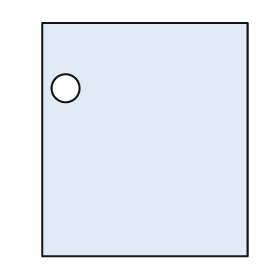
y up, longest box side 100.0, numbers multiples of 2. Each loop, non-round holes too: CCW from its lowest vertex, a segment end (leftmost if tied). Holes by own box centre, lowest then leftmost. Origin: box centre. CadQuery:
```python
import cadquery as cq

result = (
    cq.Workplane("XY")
    .moveTo(-44.0, -50.0)
    .lineTo(44.0, -50.0)
    .lineTo(44.0, 50.0)
    .lineTo(-44.0, 50.0)
    .close()
    .moveTo(-34.0, 22.0)
    .circle(6.0)
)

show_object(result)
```